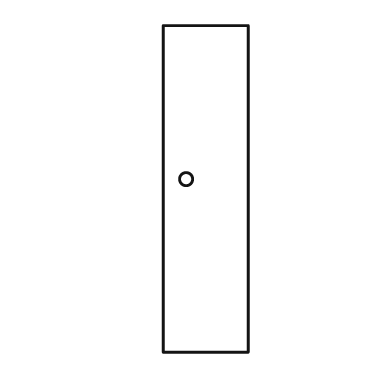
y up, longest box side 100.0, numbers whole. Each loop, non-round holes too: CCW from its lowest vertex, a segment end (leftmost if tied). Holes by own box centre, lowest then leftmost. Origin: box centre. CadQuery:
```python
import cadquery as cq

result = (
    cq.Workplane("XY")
    .moveTo(-13.0, -50.0)
    .lineTo(13.0, -50.0)
    .lineTo(13.0, 50.0)
    .lineTo(-13.0, 50.0)
    .close()
    .moveTo(-6.0, 3.0)
    .circle(2.0)
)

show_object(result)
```